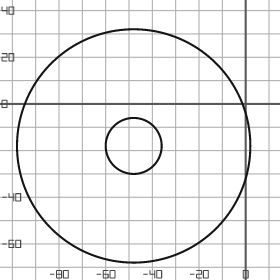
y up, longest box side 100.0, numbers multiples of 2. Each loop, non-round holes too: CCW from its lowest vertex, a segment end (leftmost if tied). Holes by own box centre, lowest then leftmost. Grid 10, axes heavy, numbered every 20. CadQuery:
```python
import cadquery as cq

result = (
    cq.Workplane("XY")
    .moveTo(-48.0, -18.0)
    .circle(50.0)
    .moveTo(-48.0, -18.0)
    .circle(12.0)
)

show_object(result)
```